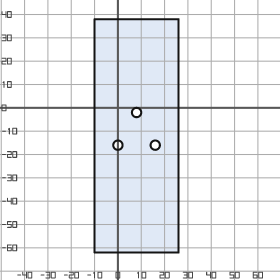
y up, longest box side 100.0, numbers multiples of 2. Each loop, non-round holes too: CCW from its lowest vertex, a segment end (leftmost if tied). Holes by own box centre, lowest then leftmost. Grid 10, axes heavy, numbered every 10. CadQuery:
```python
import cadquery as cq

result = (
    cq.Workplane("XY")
    .moveTo(-10.0, -62.0)
    .lineTo(26.0, -62.0)
    .lineTo(26.0, 38.0)
    .lineTo(-10.0, 38.0)
    .close()
    .moveTo(0.0, -16.0)
    .circle(2.0)
    .moveTo(16.0, -16.0)
    .circle(2.0)
    .moveTo(8.0, -2.0)
    .circle(2.0)
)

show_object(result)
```